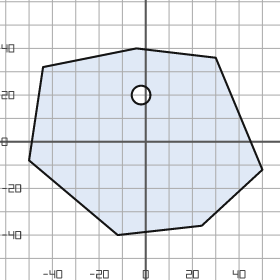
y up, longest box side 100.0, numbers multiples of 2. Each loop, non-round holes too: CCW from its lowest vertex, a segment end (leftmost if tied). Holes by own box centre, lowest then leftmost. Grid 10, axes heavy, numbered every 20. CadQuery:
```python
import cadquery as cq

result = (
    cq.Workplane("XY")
    .moveTo(-12.0, -40.0)
    .lineTo(24.0, -36.0)
    .lineTo(50.0, -12.0)
    .lineTo(30.0, 36.0)
    .lineTo(-4.0, 40.0)
    .lineTo(-44.0, 32.0)
    .lineTo(-50.0, -8.0)
    .close()
    .moveTo(-2.0, 20.0)
    .circle(4.0)
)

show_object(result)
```